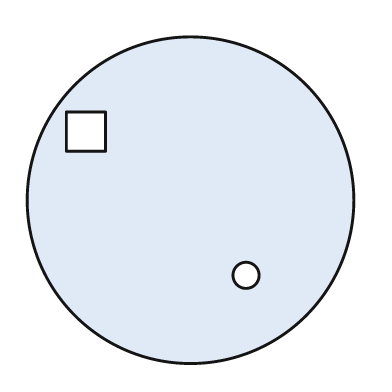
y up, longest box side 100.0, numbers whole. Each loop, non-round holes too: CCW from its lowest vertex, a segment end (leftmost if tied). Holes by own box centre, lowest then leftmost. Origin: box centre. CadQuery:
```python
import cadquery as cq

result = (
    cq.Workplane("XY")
    .moveTo(0.0, 0.0)
    .circle(50.0)
    .moveTo(17.0, -23.0)
    .circle(4.0)
    .moveTo(-38.0, 15.0)
    .lineTo(-26.0, 15.0)
    .lineTo(-26.0, 27.0)
    .lineTo(-38.0, 27.0)
    .close()
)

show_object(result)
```